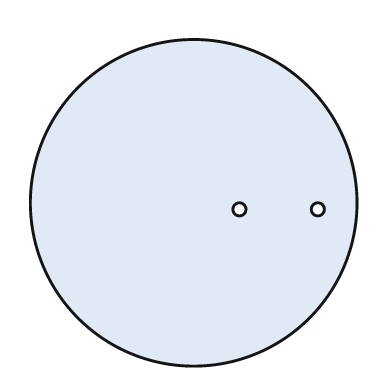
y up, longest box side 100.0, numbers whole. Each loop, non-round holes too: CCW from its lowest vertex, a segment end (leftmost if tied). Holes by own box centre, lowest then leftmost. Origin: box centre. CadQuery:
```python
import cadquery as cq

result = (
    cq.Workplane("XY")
    .moveTo(0.0, 0.0)
    .circle(50.0)
    .moveTo(14.0, -2.0)
    .circle(2.0)
    .moveTo(38.0, -2.0)
    .circle(2.0)
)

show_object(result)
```